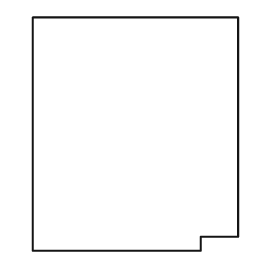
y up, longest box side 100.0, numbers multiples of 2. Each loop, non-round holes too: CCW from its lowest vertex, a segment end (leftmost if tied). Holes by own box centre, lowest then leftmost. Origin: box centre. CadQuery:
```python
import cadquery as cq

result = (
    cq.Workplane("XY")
    .moveTo(-44.0, -50.0)
    .lineTo(28.0, -50.0)
    .lineTo(28.0, -44.0)
    .lineTo(44.0, -44.0)
    .lineTo(44.0, 50.0)
    .lineTo(-44.0, 50.0)
    .close()
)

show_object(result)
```